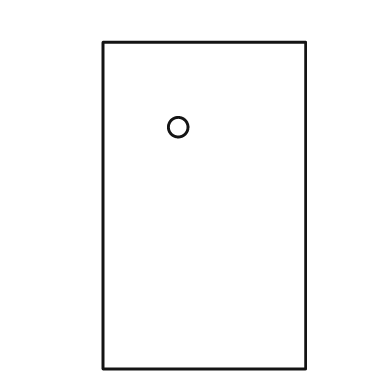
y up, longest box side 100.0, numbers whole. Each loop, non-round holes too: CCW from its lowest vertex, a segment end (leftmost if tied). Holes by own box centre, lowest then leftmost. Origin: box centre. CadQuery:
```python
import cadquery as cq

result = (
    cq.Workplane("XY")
    .moveTo(-31.0, -50.0)
    .lineTo(31.0, -50.0)
    .lineTo(31.0, 50.0)
    .lineTo(-31.0, 50.0)
    .close()
    .moveTo(-8.0, 24.0)
    .circle(3.0)
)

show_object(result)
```